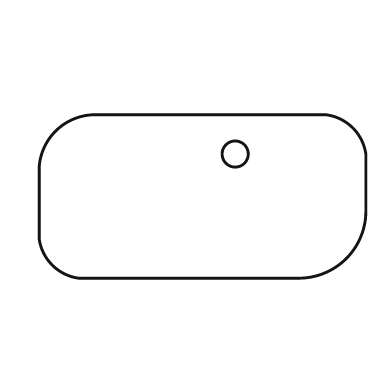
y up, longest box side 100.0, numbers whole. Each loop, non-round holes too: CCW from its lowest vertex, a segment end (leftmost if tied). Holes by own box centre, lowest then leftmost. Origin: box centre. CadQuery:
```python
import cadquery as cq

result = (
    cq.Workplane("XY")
    .moveTo(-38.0, -25.0)
    .lineTo(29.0, -25.0)
    .threePointArc((44.0, -19.0), (50.0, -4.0))
    .lineTo(50.0, 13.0)
    .threePointArc((46.0, 21.0), (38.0, 25.0))
    .lineTo(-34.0, 25.0)
    .threePointArc((-45.0, 20.0), (-50.0, 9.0))
    .lineTo(-50.0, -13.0)
    .threePointArc((-46.0, -21.0), (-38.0, -25.0))
    .close()
    .moveTo(10.0, 13.0)
    .circle(4.0)
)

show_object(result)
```